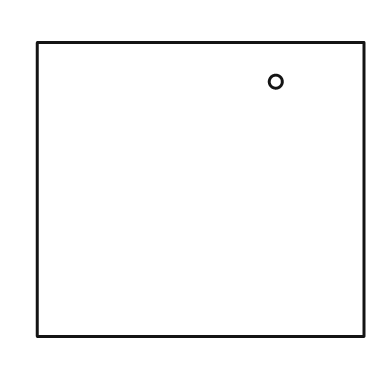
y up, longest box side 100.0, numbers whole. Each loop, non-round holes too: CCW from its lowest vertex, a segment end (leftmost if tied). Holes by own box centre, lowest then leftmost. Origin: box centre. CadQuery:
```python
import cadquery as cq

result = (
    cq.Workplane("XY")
    .moveTo(-50.0, -45.0)
    .lineTo(50.0, -45.0)
    .lineTo(50.0, 45.0)
    .lineTo(-50.0, 45.0)
    .close()
    .moveTo(23.0, 33.0)
    .circle(2.0)
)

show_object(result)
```